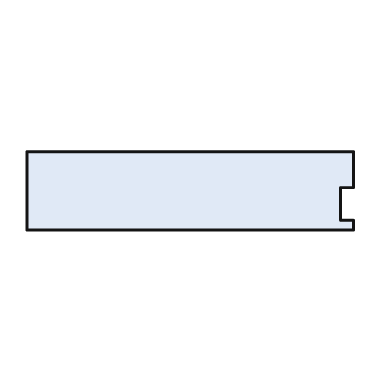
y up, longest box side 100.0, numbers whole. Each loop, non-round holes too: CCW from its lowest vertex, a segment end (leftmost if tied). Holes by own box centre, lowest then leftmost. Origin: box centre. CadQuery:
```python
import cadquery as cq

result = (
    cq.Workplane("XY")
    .moveTo(-50.0, -12.0)
    .lineTo(50.0, -12.0)
    .lineTo(50.0, -9.0)
    .lineTo(46.0, -9.0)
    .lineTo(46.0, 1.0)
    .lineTo(50.0, 1.0)
    .lineTo(50.0, 12.0)
    .lineTo(-50.0, 12.0)
    .close()
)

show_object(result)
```